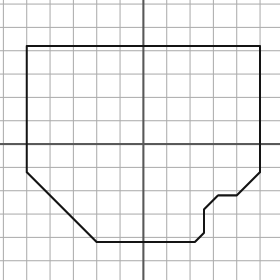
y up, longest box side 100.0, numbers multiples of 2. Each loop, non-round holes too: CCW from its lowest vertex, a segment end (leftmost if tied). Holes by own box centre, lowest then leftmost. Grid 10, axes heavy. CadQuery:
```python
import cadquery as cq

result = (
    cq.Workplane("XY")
    .moveTo(-20.0, -42.0)
    .lineTo(22.0, -42.0)
    .lineTo(26.0, -38.0)
    .lineTo(26.0, -28.0)
    .lineTo(32.0, -22.0)
    .lineTo(40.0, -22.0)
    .lineTo(50.0, -12.0)
    .lineTo(50.0, 42.0)
    .lineTo(-50.0, 42.0)
    .lineTo(-50.0, -12.0)
    .close()
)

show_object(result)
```